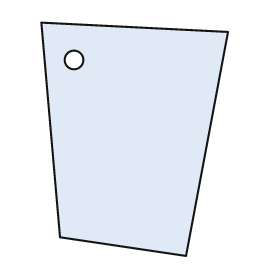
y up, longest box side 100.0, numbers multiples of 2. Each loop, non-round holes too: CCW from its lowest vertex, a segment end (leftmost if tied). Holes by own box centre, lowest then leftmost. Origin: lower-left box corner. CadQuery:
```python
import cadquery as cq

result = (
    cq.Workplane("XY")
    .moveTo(62.0, 0.0)
    .lineTo(80.0, 96.0)
    .lineTo(0.0, 100.0)
    .lineTo(8.0, 8.0)
    .close()
    .moveTo(14.0, 84.0)
    .circle(4.0)
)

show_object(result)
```